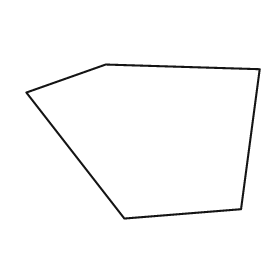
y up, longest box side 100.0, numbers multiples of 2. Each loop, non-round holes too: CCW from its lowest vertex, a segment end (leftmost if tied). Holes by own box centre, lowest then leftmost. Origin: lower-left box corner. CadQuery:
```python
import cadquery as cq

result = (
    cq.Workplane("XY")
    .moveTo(42.0, 0.0)
    .lineTo(92.0, 4.0)
    .lineTo(100.0, 64.0)
    .lineTo(34.0, 66.0)
    .lineTo(0.0, 54.0)
    .close()
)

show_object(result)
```